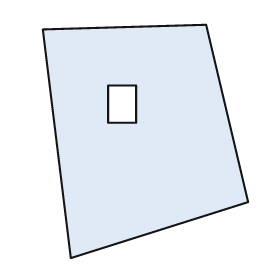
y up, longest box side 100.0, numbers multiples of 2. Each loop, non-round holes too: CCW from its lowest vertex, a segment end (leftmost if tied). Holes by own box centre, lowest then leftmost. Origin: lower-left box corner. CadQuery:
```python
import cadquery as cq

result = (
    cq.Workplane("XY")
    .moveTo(12.0, 0.0)
    .lineTo(88.0, 24.0)
    .lineTo(70.0, 100.0)
    .lineTo(0.0, 98.0)
    .close()
    .moveTo(28.0, 58.0)
    .lineTo(40.0, 58.0)
    .lineTo(40.0, 74.0)
    .lineTo(28.0, 74.0)
    .close()
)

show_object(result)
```